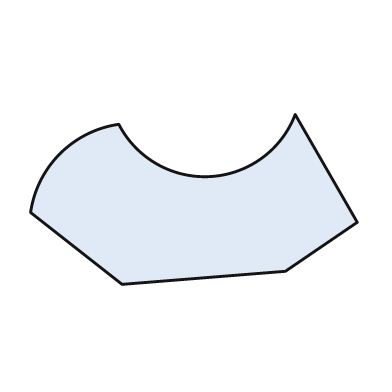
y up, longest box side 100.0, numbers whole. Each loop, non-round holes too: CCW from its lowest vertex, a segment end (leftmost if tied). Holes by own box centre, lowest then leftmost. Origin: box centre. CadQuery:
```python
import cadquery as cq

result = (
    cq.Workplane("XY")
    .moveTo(-22.0, -26.0)
    .lineTo(28.0, -22.0)
    .lineTo(50.0, -7.0)
    .lineTo(31.0, 26.0)
    .threePointArc((5.0, 7.0), (-23.0, 23.0))
    .threePointArc((-41.0, 14.0), (-50.0, -4.0))
    .close()
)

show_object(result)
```